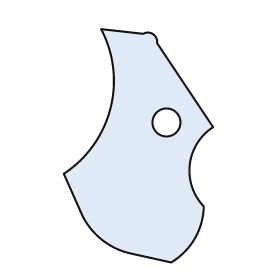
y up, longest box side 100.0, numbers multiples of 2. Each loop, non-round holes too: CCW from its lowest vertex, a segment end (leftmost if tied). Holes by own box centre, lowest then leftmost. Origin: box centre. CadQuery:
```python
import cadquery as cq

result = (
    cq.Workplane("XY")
    .moveTo(14.0, -50.0)
    .threePointArc((24.0, -40.0), (28.0, -26.0))
    .threePointArc((22.0, -8.0), (32.0, 8.0))
    .lineTo(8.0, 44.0)
    .threePointArc((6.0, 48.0), (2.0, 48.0))
    .lineTo(-16.0, 50.0)
    .threePointArc((-12.0, 16.0), (-32.0, -12.0))
    .lineTo(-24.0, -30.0)
    .threePointArc((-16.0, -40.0), (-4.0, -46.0))
    .close()
    .moveTo(12.0, 10.0)
    .circle(6.0)
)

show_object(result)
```